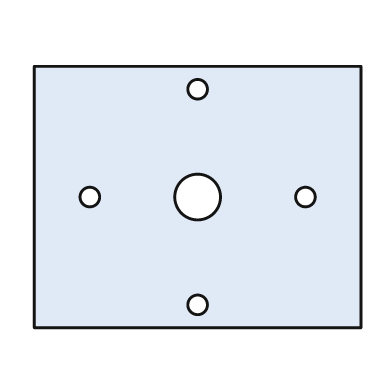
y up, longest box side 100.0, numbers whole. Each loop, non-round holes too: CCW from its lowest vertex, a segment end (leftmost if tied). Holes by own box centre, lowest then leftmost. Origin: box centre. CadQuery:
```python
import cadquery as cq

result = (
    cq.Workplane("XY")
    .moveTo(-50.0, -40.0)
    .lineTo(50.0, -40.0)
    .lineTo(50.0, 40.0)
    .lineTo(-50.0, 40.0)
    .close()
    .moveTo(0.0, -33.0)
    .circle(3.0)
    .moveTo(-33.0, 0.0)
    .circle(3.0)
    .moveTo(0.0, 0.0)
    .circle(7.0)
    .moveTo(33.0, 0.0)
    .circle(3.0)
    .moveTo(0.0, 33.0)
    .circle(3.0)
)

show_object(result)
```